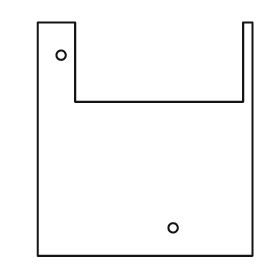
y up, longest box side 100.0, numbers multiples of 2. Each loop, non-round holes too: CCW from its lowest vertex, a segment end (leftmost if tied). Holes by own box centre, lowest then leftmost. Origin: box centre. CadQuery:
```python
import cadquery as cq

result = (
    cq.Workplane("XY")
    .moveTo(-46.0, -50.0)
    .lineTo(46.0, -50.0)
    .lineTo(46.0, 50.0)
    .lineTo(42.0, 50.0)
    .lineTo(42.0, 16.0)
    .lineTo(-30.0, 16.0)
    .lineTo(-30.0, 50.0)
    .lineTo(-46.0, 50.0)
    .close()
    .moveTo(12.0, -38.0)
    .circle(2.0)
    .moveTo(-36.0, 36.0)
    .circle(2.0)
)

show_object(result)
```